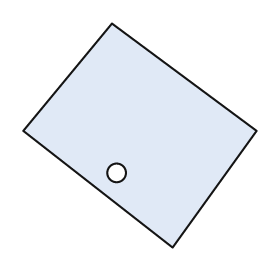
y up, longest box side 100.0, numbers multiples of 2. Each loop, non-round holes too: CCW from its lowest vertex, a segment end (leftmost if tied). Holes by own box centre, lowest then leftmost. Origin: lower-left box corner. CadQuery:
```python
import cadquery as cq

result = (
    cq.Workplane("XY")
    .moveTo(64.0, 0.0)
    .lineTo(100.0, 50.0)
    .lineTo(38.0, 96.0)
    .lineTo(0.0, 50.0)
    .close()
    .moveTo(40.0, 32.0)
    .circle(4.0)
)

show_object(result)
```